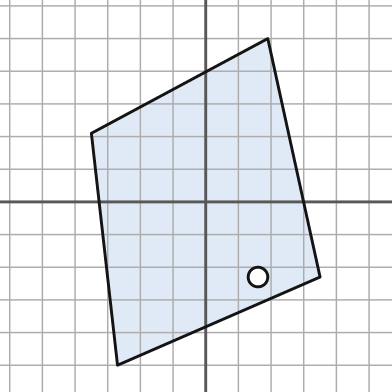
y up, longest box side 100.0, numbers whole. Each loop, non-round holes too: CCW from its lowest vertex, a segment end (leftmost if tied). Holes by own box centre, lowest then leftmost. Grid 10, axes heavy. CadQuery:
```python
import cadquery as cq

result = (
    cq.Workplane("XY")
    .moveTo(-27.0, -50.0)
    .lineTo(35.0, -23.0)
    .lineTo(19.0, 50.0)
    .lineTo(-35.0, 21.0)
    .close()
    .moveTo(16.0, -23.0)
    .circle(3.0)
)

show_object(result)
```